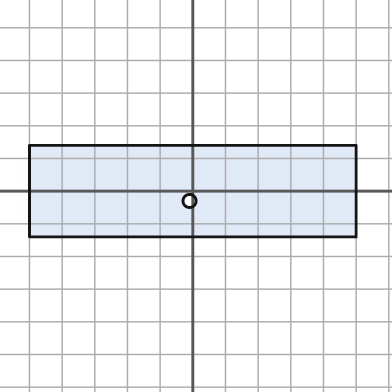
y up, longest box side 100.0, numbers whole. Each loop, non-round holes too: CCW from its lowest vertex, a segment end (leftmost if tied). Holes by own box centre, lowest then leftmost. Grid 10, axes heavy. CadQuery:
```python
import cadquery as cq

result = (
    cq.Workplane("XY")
    .moveTo(-50.0, -14.0)
    .lineTo(50.0, -14.0)
    .lineTo(50.0, 14.0)
    .lineTo(-50.0, 14.0)
    .close()
    .moveTo(-1.0, -3.0)
    .circle(2.0)
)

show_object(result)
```